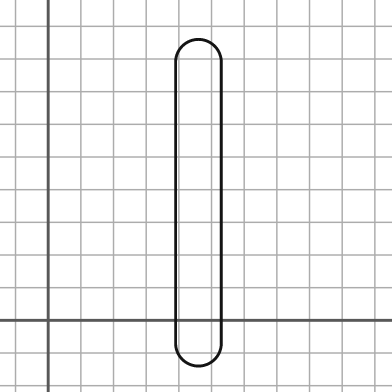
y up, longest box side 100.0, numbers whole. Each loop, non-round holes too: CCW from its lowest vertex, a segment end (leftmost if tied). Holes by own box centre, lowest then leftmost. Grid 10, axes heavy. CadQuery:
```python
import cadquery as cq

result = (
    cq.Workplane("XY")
    .moveTo(39.0, -7.0)
    .threePointArc((46.0, -14.0), (53.0, -7.0))
    .lineTo(53.0, 79.0)
    .threePointArc((46.0, 86.0), (39.0, 79.0))
    .close()
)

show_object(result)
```